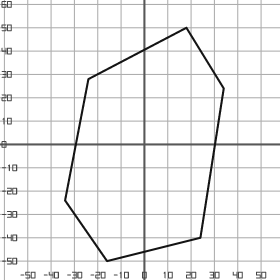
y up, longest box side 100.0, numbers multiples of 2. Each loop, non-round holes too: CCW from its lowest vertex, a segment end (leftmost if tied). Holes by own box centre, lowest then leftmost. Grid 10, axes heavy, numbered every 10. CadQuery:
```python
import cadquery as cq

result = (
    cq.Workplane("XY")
    .moveTo(-16.0, -50.0)
    .lineTo(24.0, -40.0)
    .lineTo(34.0, 24.0)
    .lineTo(18.0, 50.0)
    .lineTo(-24.0, 28.0)
    .lineTo(-34.0, -24.0)
    .close()
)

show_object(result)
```